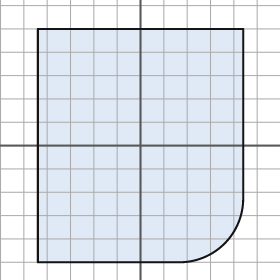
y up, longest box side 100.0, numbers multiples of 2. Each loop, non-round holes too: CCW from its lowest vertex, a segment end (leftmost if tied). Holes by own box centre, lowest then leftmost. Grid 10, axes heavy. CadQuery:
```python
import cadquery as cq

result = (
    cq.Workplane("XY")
    .moveTo(-44.0, -50.0)
    .lineTo(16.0, -50.0)
    .threePointArc((36.0, -42.0), (44.0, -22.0))
    .lineTo(44.0, 50.0)
    .lineTo(-44.0, 50.0)
    .close()
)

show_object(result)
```